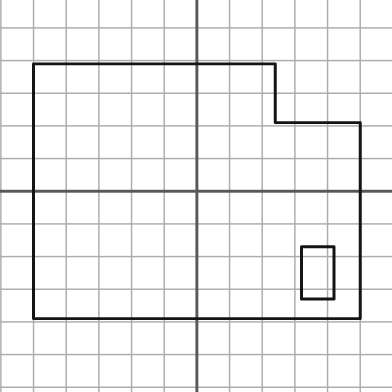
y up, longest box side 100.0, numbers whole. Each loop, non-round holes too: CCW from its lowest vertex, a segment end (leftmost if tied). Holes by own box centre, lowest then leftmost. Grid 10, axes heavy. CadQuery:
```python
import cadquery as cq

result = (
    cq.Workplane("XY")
    .moveTo(-50.0, -39.0)
    .lineTo(50.0, -39.0)
    .lineTo(50.0, 21.0)
    .lineTo(24.0, 21.0)
    .lineTo(24.0, 39.0)
    .lineTo(-50.0, 39.0)
    .close()
    .moveTo(32.0, -33.0)
    .lineTo(42.0, -33.0)
    .lineTo(42.0, -17.0)
    .lineTo(32.0, -17.0)
    .close()
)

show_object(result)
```